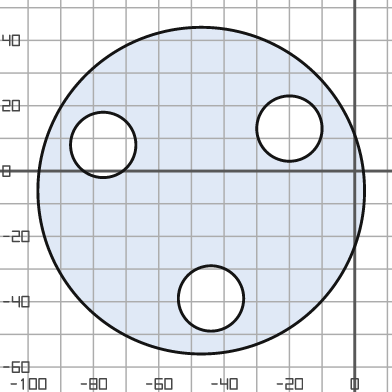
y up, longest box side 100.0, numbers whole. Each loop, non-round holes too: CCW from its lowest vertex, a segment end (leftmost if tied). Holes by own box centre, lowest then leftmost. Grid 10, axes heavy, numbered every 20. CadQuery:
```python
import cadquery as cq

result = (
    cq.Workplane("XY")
    .moveTo(-47.0, -6.0)
    .circle(50.0)
    .moveTo(-44.0, -39.0)
    .circle(10.0)
    .moveTo(-77.0, 8.0)
    .circle(10.0)
    .moveTo(-20.0, 13.0)
    .circle(10.0)
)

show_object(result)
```